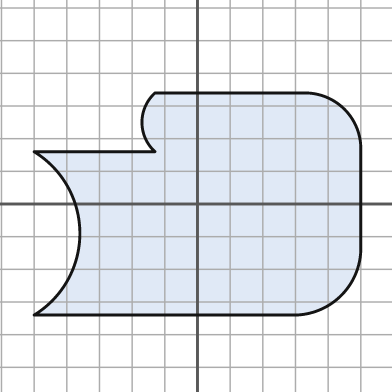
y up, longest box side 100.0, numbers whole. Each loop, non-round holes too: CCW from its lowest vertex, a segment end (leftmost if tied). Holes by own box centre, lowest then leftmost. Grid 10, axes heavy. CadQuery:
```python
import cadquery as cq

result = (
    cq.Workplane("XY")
    .moveTo(-50.0, -34.0)
    .lineTo(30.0, -34.0)
    .threePointArc((44.0, -28.0), (50.0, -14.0))
    .lineTo(50.0, 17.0)
    .threePointArc((45.0, 29.0), (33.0, 34.0))
    .lineTo(-13.0, 34.0)
    .threePointArc((-17.0, 25.0), (-13.0, 16.0))
    .lineTo(-50.0, 16.0)
    .threePointArc((-36.0, -9.0), (-50.0, -34.0))
    .close()
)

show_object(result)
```